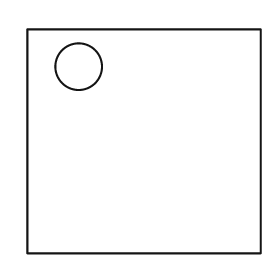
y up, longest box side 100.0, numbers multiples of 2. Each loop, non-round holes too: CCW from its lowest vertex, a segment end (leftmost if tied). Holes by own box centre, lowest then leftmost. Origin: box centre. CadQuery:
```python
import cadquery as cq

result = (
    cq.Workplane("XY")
    .moveTo(-50.0, -48.0)
    .lineTo(50.0, -48.0)
    .lineTo(50.0, 48.0)
    .lineTo(-50.0, 48.0)
    .close()
    .moveTo(-28.0, 32.0)
    .circle(10.0)
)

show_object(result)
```